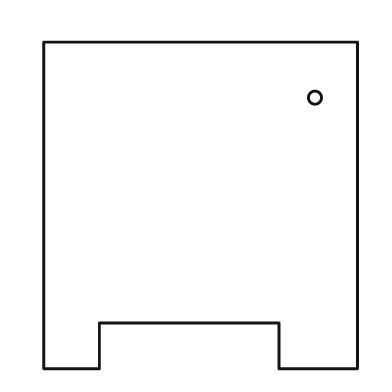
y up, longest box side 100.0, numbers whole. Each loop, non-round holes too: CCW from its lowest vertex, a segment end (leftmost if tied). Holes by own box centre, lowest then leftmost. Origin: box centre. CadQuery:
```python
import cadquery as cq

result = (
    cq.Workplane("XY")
    .moveTo(-48.0, -50.0)
    .lineTo(-31.0, -50.0)
    .lineTo(-31.0, -36.0)
    .lineTo(24.0, -36.0)
    .lineTo(24.0, -50.0)
    .lineTo(48.0, -50.0)
    .lineTo(48.0, 50.0)
    .lineTo(-48.0, 50.0)
    .close()
    .moveTo(35.0, 33.0)
    .circle(2.0)
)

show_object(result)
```